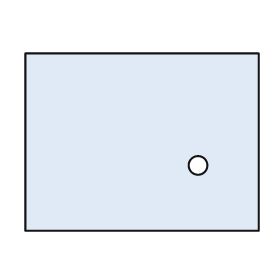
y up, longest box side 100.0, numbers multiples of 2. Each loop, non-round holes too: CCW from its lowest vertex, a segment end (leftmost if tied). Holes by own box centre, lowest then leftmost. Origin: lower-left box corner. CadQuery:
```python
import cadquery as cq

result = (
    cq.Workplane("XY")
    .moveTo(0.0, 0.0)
    .lineTo(100.0, 0.0)
    .lineTo(100.0, 76.0)
    .lineTo(0.0, 76.0)
    .close()
    .moveTo(74.0, 28.0)
    .circle(4.0)
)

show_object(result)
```